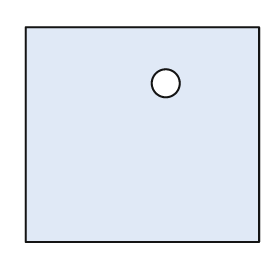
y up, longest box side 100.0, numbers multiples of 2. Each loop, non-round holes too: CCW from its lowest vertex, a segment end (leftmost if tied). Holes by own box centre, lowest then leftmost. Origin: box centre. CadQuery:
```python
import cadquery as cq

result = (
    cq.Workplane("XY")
    .moveTo(-50.0, -46.0)
    .lineTo(50.0, -46.0)
    .lineTo(50.0, 46.0)
    .lineTo(-50.0, 46.0)
    .close()
    .moveTo(10.0, 22.0)
    .circle(6.0)
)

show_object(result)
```